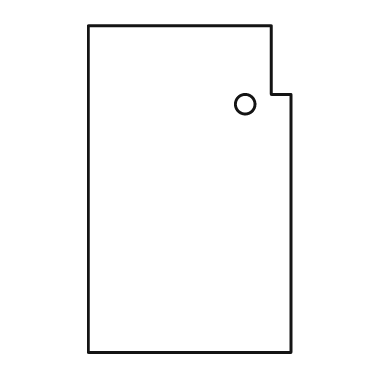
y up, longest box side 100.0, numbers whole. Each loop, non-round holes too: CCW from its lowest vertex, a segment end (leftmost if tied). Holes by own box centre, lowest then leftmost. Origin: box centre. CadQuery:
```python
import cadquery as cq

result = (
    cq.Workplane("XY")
    .moveTo(-31.0, -50.0)
    .lineTo(31.0, -50.0)
    .lineTo(31.0, 29.0)
    .lineTo(25.0, 29.0)
    .lineTo(25.0, 50.0)
    .lineTo(-31.0, 50.0)
    .close()
    .moveTo(17.0, 26.0)
    .circle(3.0)
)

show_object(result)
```